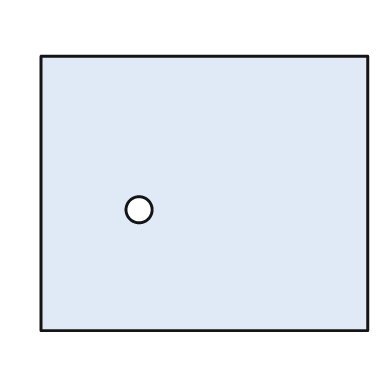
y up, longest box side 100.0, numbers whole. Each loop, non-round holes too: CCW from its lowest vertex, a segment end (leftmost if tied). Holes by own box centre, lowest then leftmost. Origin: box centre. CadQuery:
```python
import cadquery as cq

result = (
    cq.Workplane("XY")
    .moveTo(-50.0, -42.0)
    .lineTo(50.0, -42.0)
    .lineTo(50.0, 42.0)
    .lineTo(-50.0, 42.0)
    .close()
    .moveTo(-20.0, -5.0)
    .circle(4.0)
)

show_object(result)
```